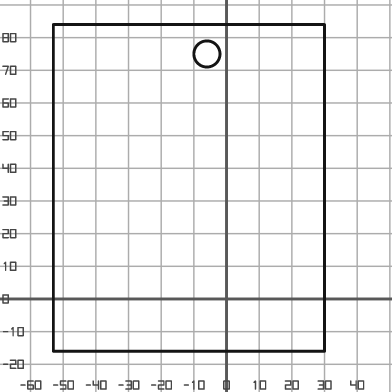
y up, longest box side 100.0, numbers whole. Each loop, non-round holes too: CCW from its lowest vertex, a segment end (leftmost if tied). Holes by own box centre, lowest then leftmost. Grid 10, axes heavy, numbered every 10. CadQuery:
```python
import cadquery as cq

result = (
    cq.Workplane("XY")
    .moveTo(-53.0, -16.0)
    .lineTo(30.0, -16.0)
    .lineTo(30.0, 84.0)
    .lineTo(-53.0, 84.0)
    .close()
    .moveTo(-6.0, 75.0)
    .circle(4.0)
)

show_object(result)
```